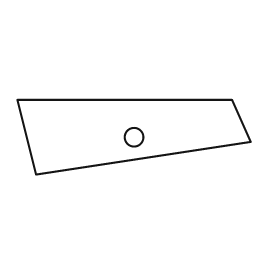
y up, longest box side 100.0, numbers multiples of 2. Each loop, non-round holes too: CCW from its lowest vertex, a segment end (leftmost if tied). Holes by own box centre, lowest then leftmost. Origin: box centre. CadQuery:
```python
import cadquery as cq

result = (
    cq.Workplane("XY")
    .moveTo(-42.0, -16.0)
    .lineTo(50.0, -2.0)
    .lineTo(42.0, 16.0)
    .lineTo(-50.0, 16.0)
    .close()
    .moveTo(0.0, 0.0)
    .circle(4.0)
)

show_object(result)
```